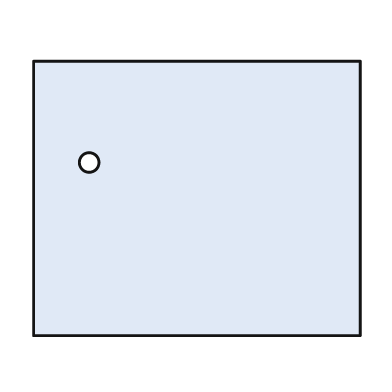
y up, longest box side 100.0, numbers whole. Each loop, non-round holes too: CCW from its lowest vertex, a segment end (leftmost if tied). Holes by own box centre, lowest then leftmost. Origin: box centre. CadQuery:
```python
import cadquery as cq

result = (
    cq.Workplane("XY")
    .moveTo(-50.0, -42.0)
    .lineTo(50.0, -42.0)
    .lineTo(50.0, 42.0)
    .lineTo(-50.0, 42.0)
    .close()
    .moveTo(-33.0, 11.0)
    .circle(3.0)
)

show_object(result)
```